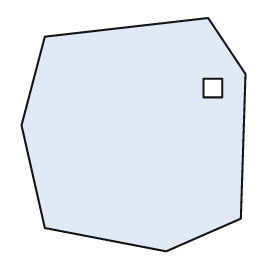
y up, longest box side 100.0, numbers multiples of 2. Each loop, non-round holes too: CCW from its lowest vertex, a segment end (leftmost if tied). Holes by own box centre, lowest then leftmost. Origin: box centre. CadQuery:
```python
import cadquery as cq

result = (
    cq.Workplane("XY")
    .moveTo(14.0, -50.0)
    .lineTo(46.0, -36.0)
    .lineTo(48.0, 26.0)
    .lineTo(32.0, 50.0)
    .lineTo(-38.0, 42.0)
    .lineTo(-48.0, 4.0)
    .lineTo(-38.0, -40.0)
    .close()
    .moveTo(30.0, 16.0)
    .lineTo(38.0, 16.0)
    .lineTo(38.0, 24.0)
    .lineTo(30.0, 24.0)
    .close()
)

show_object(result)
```